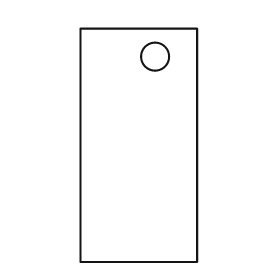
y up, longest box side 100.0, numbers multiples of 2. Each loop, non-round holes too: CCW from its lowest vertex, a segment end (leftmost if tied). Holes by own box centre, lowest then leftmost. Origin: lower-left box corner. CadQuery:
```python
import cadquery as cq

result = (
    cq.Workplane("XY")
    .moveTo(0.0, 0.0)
    .lineTo(50.0, 0.0)
    .lineTo(50.0, 100.0)
    .lineTo(0.0, 100.0)
    .close()
    .moveTo(32.0, 88.0)
    .circle(6.0)
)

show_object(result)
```